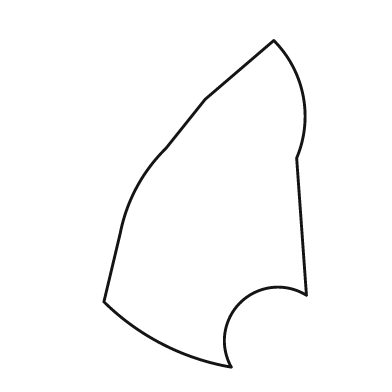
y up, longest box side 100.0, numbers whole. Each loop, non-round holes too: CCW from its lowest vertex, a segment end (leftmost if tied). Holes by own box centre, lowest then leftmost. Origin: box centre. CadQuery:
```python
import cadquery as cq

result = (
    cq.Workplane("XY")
    .moveTo(8.0, -50.0)
    .threePointArc((11.0, -30.0), (31.0, -28.0))
    .lineTo(28.0, 14.0)
    .threePointArc((30.0, 33.0), (21.0, 50.0))
    .lineTo(0.0, 32.0)
    .lineTo(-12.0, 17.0)
    .threePointArc((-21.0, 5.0), (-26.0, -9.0))
    .lineTo(-31.0, -30.0)
    .threePointArc((-13.0, -43.0), (8.0, -50.0))
    .close()
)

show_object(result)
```